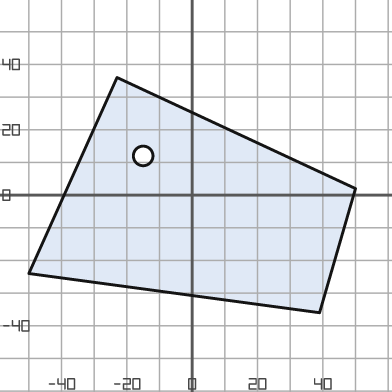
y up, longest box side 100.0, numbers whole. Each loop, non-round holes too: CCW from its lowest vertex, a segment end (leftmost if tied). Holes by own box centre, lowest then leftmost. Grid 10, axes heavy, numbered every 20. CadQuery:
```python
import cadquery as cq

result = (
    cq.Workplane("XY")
    .moveTo(39.0, -36.0)
    .lineTo(50.0, 2.0)
    .lineTo(-23.0, 36.0)
    .lineTo(-50.0, -24.0)
    .close()
    .moveTo(-15.0, 12.0)
    .circle(3.0)
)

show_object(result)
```